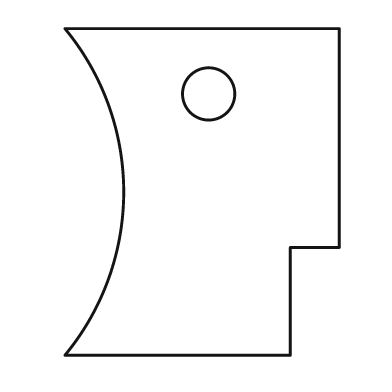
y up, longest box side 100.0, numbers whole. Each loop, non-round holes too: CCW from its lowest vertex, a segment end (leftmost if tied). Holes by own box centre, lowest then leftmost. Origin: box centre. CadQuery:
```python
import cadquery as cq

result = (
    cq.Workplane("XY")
    .moveTo(-42.0, -50.0)
    .lineTo(27.0, -50.0)
    .lineTo(27.0, -17.0)
    .lineTo(42.0, -17.0)
    .lineTo(42.0, 50.0)
    .lineTo(-42.0, 50.0)
    .threePointArc((-24.0, 0.0), (-42.0, -50.0))
    .close()
    .moveTo(2.0, 30.0)
    .circle(8.0)
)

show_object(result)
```